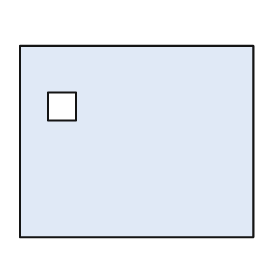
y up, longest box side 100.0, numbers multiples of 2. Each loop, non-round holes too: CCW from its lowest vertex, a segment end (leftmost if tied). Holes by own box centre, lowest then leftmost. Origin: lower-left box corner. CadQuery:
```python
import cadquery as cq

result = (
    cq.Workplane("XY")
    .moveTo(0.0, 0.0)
    .lineTo(100.0, 0.0)
    .lineTo(100.0, 82.0)
    .lineTo(0.0, 82.0)
    .close()
    .moveTo(12.0, 50.0)
    .lineTo(24.0, 50.0)
    .lineTo(24.0, 62.0)
    .lineTo(12.0, 62.0)
    .close()
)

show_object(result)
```